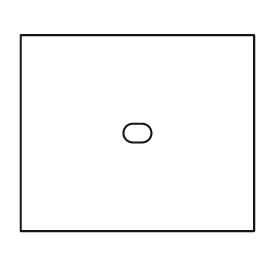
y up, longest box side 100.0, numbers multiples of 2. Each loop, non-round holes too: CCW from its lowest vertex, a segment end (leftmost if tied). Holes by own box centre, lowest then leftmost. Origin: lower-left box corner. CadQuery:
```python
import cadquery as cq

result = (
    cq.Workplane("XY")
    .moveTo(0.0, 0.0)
    .lineTo(100.0, 0.0)
    .lineTo(100.0, 84.0)
    .lineTo(0.0, 84.0)
    .close()
    .moveTo(48.0, 38.0)
    .lineTo(52.0, 38.0)
    .threePointArc((56.0, 42.0), (52.0, 46.0))
    .lineTo(48.0, 46.0)
    .threePointArc((44.0, 42.0), (48.0, 38.0))
    .close()
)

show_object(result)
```